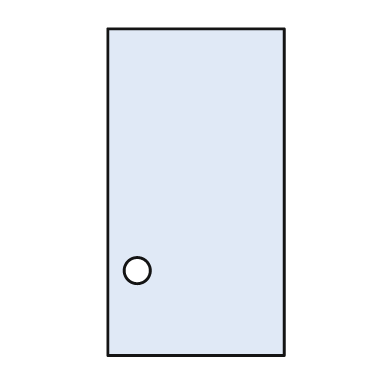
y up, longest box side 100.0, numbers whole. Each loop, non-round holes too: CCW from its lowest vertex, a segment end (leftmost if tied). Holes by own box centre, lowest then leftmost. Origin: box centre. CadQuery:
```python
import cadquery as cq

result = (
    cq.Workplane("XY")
    .moveTo(-27.0, -50.0)
    .lineTo(27.0, -50.0)
    .lineTo(27.0, 50.0)
    .lineTo(-27.0, 50.0)
    .close()
    .moveTo(-18.0, -24.0)
    .circle(4.0)
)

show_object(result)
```